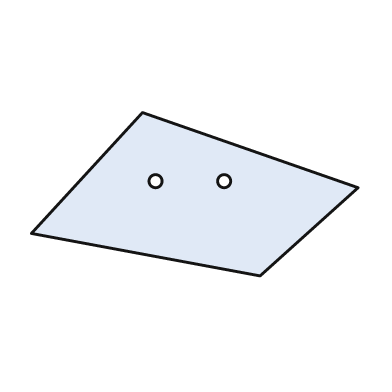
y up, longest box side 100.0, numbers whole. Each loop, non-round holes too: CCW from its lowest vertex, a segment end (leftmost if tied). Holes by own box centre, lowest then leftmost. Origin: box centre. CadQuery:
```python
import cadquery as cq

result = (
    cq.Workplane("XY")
    .moveTo(20.0, -25.0)
    .lineTo(50.0, 2.0)
    .lineTo(-16.0, 25.0)
    .lineTo(-50.0, -12.0)
    .close()
    .moveTo(-12.0, 4.0)
    .circle(2.0)
    .moveTo(9.0, 4.0)
    .circle(2.0)
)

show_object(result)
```